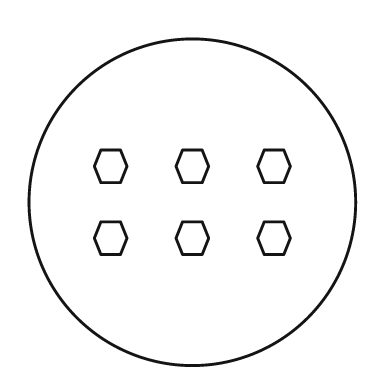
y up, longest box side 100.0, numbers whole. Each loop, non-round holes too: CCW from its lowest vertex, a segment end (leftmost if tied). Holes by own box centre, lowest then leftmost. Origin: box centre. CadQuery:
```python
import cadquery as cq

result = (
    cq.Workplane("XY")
    .moveTo(0.0, 0.0)
    .circle(50.0)
    .moveTo(-28.0, -16.0)
    .lineTo(-22.0, -16.0)
    .lineTo(-20.0, -11.0)
    .lineTo(-22.0, -6.0)
    .lineTo(-28.0, -6.0)
    .lineTo(-30.0, -11.0)
    .close()
    .moveTo(-3.0, -16.0)
    .lineTo(3.0, -16.0)
    .lineTo(5.0, -11.0)
    .lineTo(3.0, -6.0)
    .lineTo(-3.0, -6.0)
    .lineTo(-5.0, -11.0)
    .close()
    .moveTo(22.0, -16.0)
    .lineTo(28.0, -16.0)
    .lineTo(30.0, -11.0)
    .lineTo(28.0, -6.0)
    .lineTo(22.0, -6.0)
    .lineTo(20.0, -11.0)
    .close()
    .moveTo(-28.0, 6.0)
    .lineTo(-22.0, 6.0)
    .lineTo(-20.0, 11.0)
    .lineTo(-22.0, 16.0)
    .lineTo(-28.0, 16.0)
    .lineTo(-30.0, 11.0)
    .close()
    .moveTo(-3.0, 6.0)
    .lineTo(3.0, 6.0)
    .lineTo(5.0, 11.0)
    .lineTo(3.0, 16.0)
    .lineTo(-3.0, 16.0)
    .lineTo(-5.0, 11.0)
    .close()
    .moveTo(22.0, 6.0)
    .lineTo(28.0, 6.0)
    .lineTo(30.0, 11.0)
    .lineTo(28.0, 16.0)
    .lineTo(22.0, 16.0)
    .lineTo(20.0, 11.0)
    .close()
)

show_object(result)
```